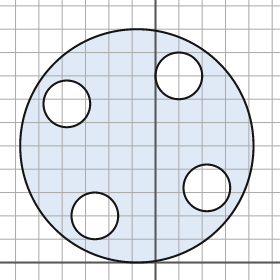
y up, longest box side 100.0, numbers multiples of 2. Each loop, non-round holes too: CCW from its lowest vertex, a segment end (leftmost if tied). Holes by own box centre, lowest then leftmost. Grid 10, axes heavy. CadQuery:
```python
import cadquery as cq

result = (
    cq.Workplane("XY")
    .moveTo(-8.0, 50.0)
    .circle(50.0)
    .moveTo(-26.0, 20.0)
    .circle(10.0)
    .moveTo(22.0, 32.0)
    .circle(10.0)
    .moveTo(-38.0, 68.0)
    .circle(10.0)
    .moveTo(10.0, 80.0)
    .circle(10.0)
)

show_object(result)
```